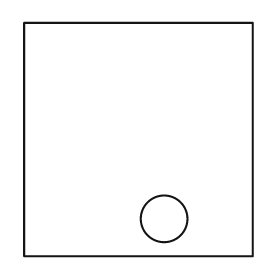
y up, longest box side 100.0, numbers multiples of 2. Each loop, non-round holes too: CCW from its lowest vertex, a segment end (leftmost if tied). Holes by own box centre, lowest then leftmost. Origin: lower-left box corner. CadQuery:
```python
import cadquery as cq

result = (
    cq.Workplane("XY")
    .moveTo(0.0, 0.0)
    .lineTo(98.0, 0.0)
    .lineTo(98.0, 100.0)
    .lineTo(0.0, 100.0)
    .close()
    .moveTo(60.0, 16.0)
    .circle(10.0)
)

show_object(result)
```